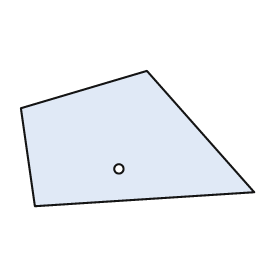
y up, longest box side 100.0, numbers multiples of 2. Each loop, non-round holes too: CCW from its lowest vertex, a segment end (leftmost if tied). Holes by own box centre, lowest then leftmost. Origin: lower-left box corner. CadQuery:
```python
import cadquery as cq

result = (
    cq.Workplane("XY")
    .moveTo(6.0, 0.0)
    .lineTo(100.0, 6.0)
    .lineTo(54.0, 58.0)
    .lineTo(0.0, 42.0)
    .close()
    .moveTo(42.0, 16.0)
    .circle(2.0)
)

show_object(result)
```